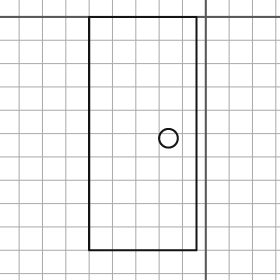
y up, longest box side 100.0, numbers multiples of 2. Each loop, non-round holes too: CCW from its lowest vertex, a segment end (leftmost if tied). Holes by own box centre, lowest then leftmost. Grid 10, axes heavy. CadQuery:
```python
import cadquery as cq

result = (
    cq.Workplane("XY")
    .moveTo(-50.0, -100.0)
    .lineTo(-4.0, -100.0)
    .lineTo(-4.0, 0.0)
    .lineTo(-50.0, 0.0)
    .close()
    .moveTo(-16.0, -52.0)
    .circle(4.0)
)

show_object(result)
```